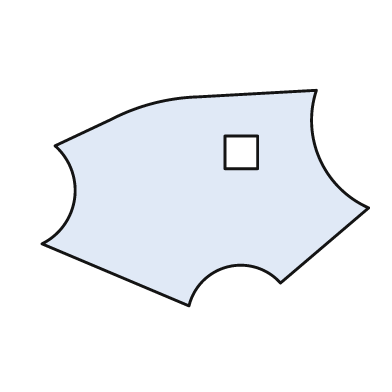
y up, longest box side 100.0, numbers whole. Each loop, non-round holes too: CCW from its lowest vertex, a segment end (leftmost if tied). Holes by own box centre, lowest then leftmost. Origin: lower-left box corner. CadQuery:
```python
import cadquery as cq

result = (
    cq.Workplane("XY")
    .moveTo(45.0, 0.0)
    .threePointArc((57.0, 12.0), (73.0, 7.0))
    .lineTo(100.0, 30.0)
    .threePointArc((85.0, 45.0), (84.0, 66.0))
    .lineTo(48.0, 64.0)
    .threePointArc((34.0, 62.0), (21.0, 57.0))
    .lineTo(4.0, 49.0)
    .threePointArc((10.0, 33.0), (0.0, 19.0))
    .close()
    .moveTo(56.0, 42.0)
    .lineTo(66.0, 42.0)
    .lineTo(66.0, 52.0)
    .lineTo(56.0, 52.0)
    .close()
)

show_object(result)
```